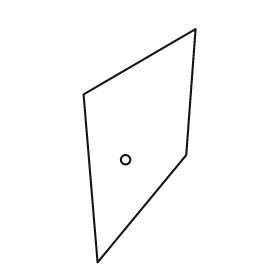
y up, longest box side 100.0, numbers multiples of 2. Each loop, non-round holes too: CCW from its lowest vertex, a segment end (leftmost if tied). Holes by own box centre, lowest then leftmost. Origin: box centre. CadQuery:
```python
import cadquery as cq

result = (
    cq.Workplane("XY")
    .moveTo(-18.0, -50.0)
    .lineTo(20.0, -4.0)
    .lineTo(24.0, 50.0)
    .lineTo(-24.0, 22.0)
    .close()
    .moveTo(-6.0, -6.0)
    .circle(2.0)
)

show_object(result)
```